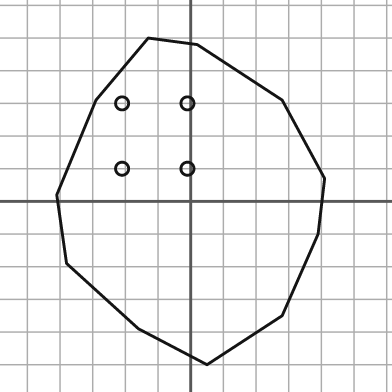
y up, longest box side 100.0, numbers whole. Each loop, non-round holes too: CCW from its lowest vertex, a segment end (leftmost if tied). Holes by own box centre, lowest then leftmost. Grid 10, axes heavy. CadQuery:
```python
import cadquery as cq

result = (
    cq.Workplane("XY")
    .moveTo(5.0, -50.0)
    .lineTo(28.0, -35.0)
    .lineTo(39.0, -10.0)
    .lineTo(41.0, 7.0)
    .lineTo(28.0, 31.0)
    .lineTo(2.0, 48.0)
    .lineTo(-13.0, 50.0)
    .lineTo(-29.0, 31.0)
    .lineTo(-41.0, 2.0)
    .lineTo(-38.0, -19.0)
    .lineTo(-16.0, -39.0)
    .close()
    .moveTo(-21.0, 10.0)
    .circle(2.0)
    .moveTo(-1.0, 10.0)
    .circle(2.0)
    .moveTo(-21.0, 30.0)
    .circle(2.0)
    .moveTo(-1.0, 30.0)
    .circle(2.0)
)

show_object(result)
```